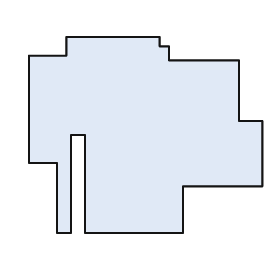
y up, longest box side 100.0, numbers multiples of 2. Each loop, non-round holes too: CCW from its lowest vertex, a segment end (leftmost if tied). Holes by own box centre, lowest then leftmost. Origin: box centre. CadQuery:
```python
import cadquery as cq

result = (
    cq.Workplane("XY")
    .moveTo(-38.0, -42.0)
    .lineTo(-32.0, -42.0)
    .lineTo(-32.0, 0.0)
    .lineTo(-26.0, 0.0)
    .lineTo(-26.0, -42.0)
    .lineTo(16.0, -42.0)
    .lineTo(16.0, -22.0)
    .lineTo(50.0, -22.0)
    .lineTo(50.0, 6.0)
    .lineTo(40.0, 6.0)
    .lineTo(40.0, 32.0)
    .lineTo(10.0, 32.0)
    .lineTo(10.0, 38.0)
    .lineTo(6.0, 38.0)
    .lineTo(6.0, 42.0)
    .lineTo(-34.0, 42.0)
    .lineTo(-34.0, 34.0)
    .lineTo(-50.0, 34.0)
    .lineTo(-50.0, -12.0)
    .lineTo(-38.0, -12.0)
    .close()
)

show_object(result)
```